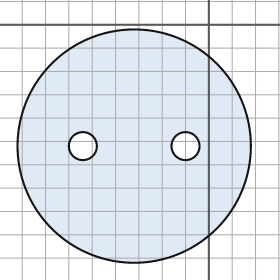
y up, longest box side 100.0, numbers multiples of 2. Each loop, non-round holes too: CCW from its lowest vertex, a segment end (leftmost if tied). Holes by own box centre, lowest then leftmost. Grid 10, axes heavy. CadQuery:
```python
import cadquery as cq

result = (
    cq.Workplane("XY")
    .moveTo(-32.0, -52.0)
    .circle(50.0)
    .moveTo(-54.0, -52.0)
    .circle(6.0)
    .moveTo(-10.0, -52.0)
    .circle(6.0)
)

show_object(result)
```